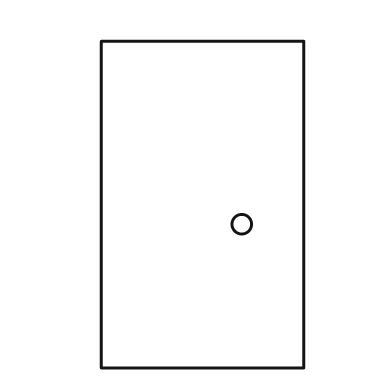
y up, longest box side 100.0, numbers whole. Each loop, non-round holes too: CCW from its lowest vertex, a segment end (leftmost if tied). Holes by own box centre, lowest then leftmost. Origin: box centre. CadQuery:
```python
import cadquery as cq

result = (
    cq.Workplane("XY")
    .moveTo(-31.0, -50.0)
    .lineTo(31.0, -50.0)
    .lineTo(31.0, 50.0)
    .lineTo(-31.0, 50.0)
    .close()
    .moveTo(12.0, -6.0)
    .circle(3.0)
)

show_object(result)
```